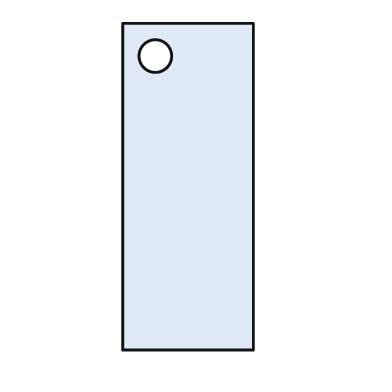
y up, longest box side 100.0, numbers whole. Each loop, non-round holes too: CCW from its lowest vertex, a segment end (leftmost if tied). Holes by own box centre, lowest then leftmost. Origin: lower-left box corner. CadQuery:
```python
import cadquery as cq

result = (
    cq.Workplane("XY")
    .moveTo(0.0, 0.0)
    .lineTo(40.0, 0.0)
    .lineTo(40.0, 100.0)
    .lineTo(0.0, 100.0)
    .close()
    .moveTo(10.0, 90.0)
    .circle(5.0)
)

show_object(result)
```